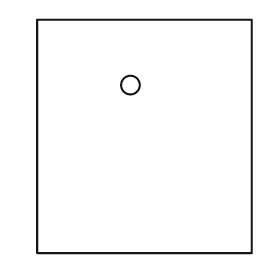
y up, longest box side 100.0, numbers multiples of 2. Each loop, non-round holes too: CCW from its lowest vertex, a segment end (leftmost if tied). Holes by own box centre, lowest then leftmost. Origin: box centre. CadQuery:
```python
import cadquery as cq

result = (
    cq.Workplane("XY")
    .moveTo(-46.0, -50.0)
    .lineTo(46.0, -50.0)
    .lineTo(46.0, 50.0)
    .lineTo(-46.0, 50.0)
    .close()
    .moveTo(-6.0, 22.0)
    .circle(4.0)
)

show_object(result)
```